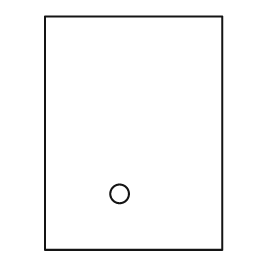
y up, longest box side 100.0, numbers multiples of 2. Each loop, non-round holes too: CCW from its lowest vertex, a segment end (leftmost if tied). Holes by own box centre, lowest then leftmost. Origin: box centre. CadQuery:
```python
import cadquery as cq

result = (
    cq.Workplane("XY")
    .moveTo(-38.0, -50.0)
    .lineTo(38.0, -50.0)
    .lineTo(38.0, 50.0)
    .lineTo(-38.0, 50.0)
    .close()
    .moveTo(-6.0, -26.0)
    .circle(4.0)
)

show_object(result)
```